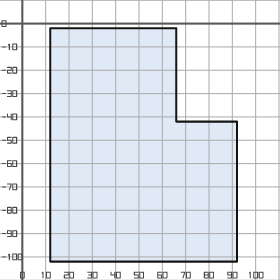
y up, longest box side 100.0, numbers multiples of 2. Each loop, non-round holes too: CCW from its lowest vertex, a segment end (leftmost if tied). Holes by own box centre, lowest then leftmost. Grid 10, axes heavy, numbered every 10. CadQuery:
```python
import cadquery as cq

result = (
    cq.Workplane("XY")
    .moveTo(12.0, -102.0)
    .lineTo(92.0, -102.0)
    .lineTo(92.0, -42.0)
    .lineTo(66.0, -42.0)
    .lineTo(66.0, -2.0)
    .lineTo(12.0, -2.0)
    .close()
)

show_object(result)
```